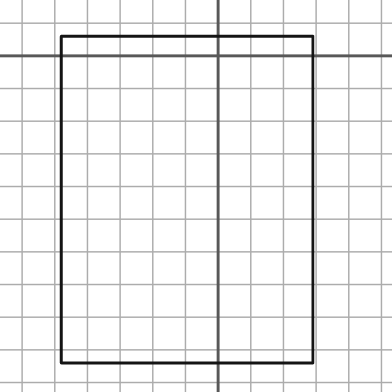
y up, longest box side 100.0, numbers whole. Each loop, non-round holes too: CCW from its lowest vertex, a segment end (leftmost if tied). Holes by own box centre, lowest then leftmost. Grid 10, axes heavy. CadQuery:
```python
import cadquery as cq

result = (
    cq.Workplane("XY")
    .moveTo(-48.0, -94.0)
    .lineTo(29.0, -94.0)
    .lineTo(29.0, 6.0)
    .lineTo(-48.0, 6.0)
    .close()
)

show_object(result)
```